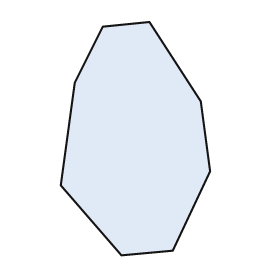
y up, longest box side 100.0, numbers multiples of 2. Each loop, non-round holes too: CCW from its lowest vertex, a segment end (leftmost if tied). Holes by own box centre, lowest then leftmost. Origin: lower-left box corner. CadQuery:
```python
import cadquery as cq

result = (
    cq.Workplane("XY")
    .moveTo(26.0, 0.0)
    .lineTo(48.0, 2.0)
    .lineTo(64.0, 36.0)
    .lineTo(60.0, 66.0)
    .lineTo(38.0, 100.0)
    .lineTo(18.0, 98.0)
    .lineTo(6.0, 74.0)
    .lineTo(0.0, 30.0)
    .close()
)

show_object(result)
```